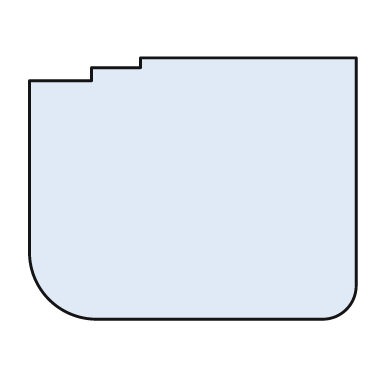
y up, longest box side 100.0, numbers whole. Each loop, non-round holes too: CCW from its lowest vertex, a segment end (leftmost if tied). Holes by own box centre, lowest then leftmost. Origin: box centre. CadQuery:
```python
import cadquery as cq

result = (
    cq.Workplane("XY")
    .moveTo(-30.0, -40.0)
    .lineTo(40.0, -40.0)
    .threePointArc((47.0, -37.0), (50.0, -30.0))
    .lineTo(50.0, 40.0)
    .lineTo(-16.0, 40.0)
    .lineTo(-16.0, 37.0)
    .lineTo(-31.0, 37.0)
    .lineTo(-31.0, 33.0)
    .lineTo(-50.0, 33.0)
    .lineTo(-50.0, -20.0)
    .threePointArc((-44.0, -34.0), (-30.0, -40.0))
    .close()
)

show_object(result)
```